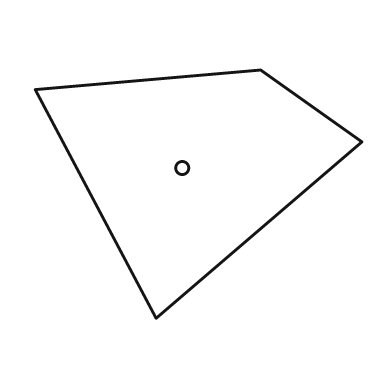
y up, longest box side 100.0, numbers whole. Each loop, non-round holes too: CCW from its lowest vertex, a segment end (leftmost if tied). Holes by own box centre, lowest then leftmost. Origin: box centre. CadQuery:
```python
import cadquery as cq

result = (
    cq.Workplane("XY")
    .moveTo(-13.0, -38.0)
    .lineTo(50.0, 16.0)
    .lineTo(19.0, 38.0)
    .lineTo(-50.0, 32.0)
    .close()
    .moveTo(-5.0, 8.0)
    .circle(2.0)
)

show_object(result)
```